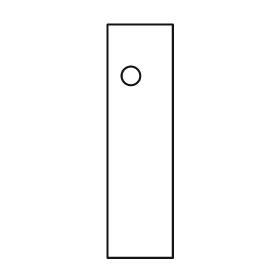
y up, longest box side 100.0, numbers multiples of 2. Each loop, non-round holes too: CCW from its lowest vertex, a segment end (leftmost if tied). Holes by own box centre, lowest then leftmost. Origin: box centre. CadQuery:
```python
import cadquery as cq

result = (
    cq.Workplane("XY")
    .moveTo(-14.0, -50.0)
    .lineTo(14.0, -50.0)
    .lineTo(14.0, 50.0)
    .lineTo(-14.0, 50.0)
    .close()
    .moveTo(-4.0, 28.0)
    .circle(4.0)
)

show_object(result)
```